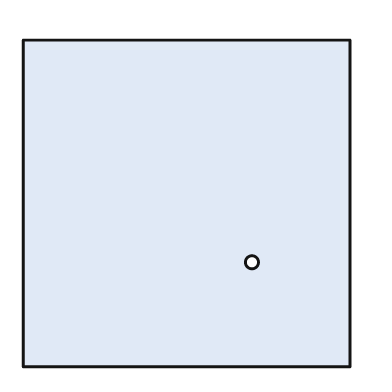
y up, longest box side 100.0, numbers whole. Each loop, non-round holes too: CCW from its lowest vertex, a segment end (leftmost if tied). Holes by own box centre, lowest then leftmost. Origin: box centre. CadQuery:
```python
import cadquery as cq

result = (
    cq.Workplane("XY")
    .moveTo(-50.0, -50.0)
    .lineTo(50.0, -50.0)
    .lineTo(50.0, 50.0)
    .lineTo(-50.0, 50.0)
    .close()
    .moveTo(20.0, -18.0)
    .circle(2.0)
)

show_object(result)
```